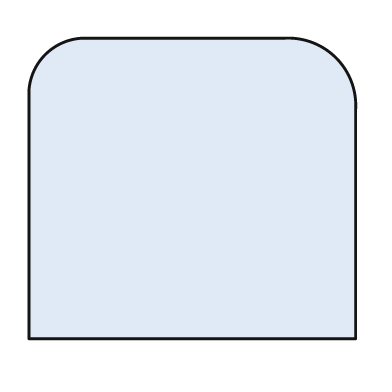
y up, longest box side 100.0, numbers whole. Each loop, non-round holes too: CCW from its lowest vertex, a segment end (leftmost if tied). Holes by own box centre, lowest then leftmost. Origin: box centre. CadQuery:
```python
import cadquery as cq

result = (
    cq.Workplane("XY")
    .moveTo(-50.0, -46.0)
    .lineTo(50.0, -46.0)
    .lineTo(50.0, 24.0)
    .threePointArc((44.0, 40.0), (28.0, 46.0))
    .lineTo(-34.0, 46.0)
    .threePointArc((-45.0, 41.0), (-50.0, 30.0))
    .close()
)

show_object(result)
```